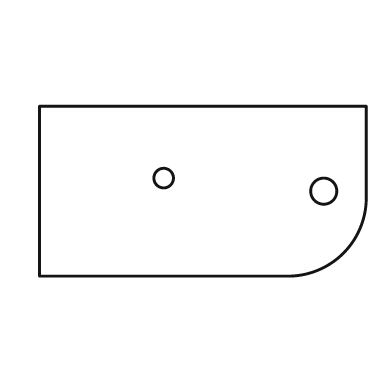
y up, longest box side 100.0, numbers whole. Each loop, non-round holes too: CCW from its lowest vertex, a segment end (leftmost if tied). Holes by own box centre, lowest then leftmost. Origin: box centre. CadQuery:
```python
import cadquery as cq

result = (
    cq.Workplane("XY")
    .moveTo(-50.0, -26.0)
    .lineTo(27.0, -26.0)
    .threePointArc((43.0, -19.0), (50.0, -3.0))
    .lineTo(50.0, 26.0)
    .lineTo(-50.0, 26.0)
    .close()
    .moveTo(37.0, 0.0)
    .circle(4.0)
    .moveTo(-12.0, 4.0)
    .circle(3.0)
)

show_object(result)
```